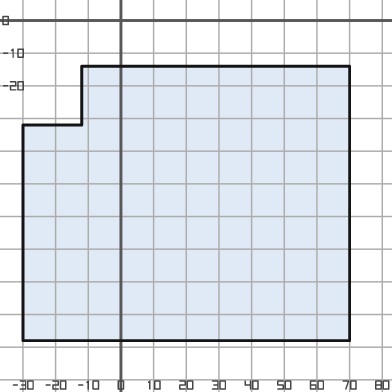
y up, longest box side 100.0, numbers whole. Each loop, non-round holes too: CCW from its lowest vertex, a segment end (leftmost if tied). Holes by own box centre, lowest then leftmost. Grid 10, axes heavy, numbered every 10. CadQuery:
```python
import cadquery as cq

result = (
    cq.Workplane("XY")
    .moveTo(-30.0, -98.0)
    .lineTo(70.0, -98.0)
    .lineTo(70.0, -14.0)
    .lineTo(-12.0, -14.0)
    .lineTo(-12.0, -32.0)
    .lineTo(-30.0, -32.0)
    .close()
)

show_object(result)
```